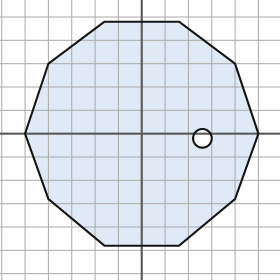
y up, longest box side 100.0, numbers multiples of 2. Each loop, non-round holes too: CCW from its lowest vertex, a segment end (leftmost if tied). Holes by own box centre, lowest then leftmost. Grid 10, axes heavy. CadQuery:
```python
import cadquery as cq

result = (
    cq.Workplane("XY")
    .moveTo(-16.0, -48.0)
    .lineTo(16.0, -48.0)
    .lineTo(40.0, -28.0)
    .lineTo(50.0, 0.0)
    .lineTo(40.0, 30.0)
    .lineTo(16.0, 48.0)
    .lineTo(-16.0, 48.0)
    .lineTo(-40.0, 30.0)
    .lineTo(-50.0, 0.0)
    .lineTo(-40.0, -28.0)
    .close()
    .moveTo(26.0, -2.0)
    .circle(4.0)
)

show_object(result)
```